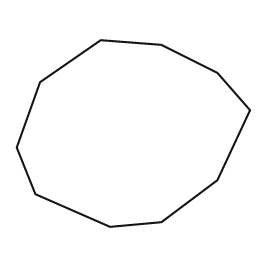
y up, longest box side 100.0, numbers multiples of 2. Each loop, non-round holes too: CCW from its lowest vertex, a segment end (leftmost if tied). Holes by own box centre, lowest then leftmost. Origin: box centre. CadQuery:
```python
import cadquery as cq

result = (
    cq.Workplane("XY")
    .moveTo(-10.0, -40.0)
    .lineTo(12.0, -38.0)
    .lineTo(36.0, -20.0)
    .lineTo(50.0, 10.0)
    .lineTo(36.0, 26.0)
    .lineTo(12.0, 38.0)
    .lineTo(-14.0, 40.0)
    .lineTo(-40.0, 22.0)
    .lineTo(-50.0, -6.0)
    .lineTo(-42.0, -26.0)
    .close()
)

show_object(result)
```